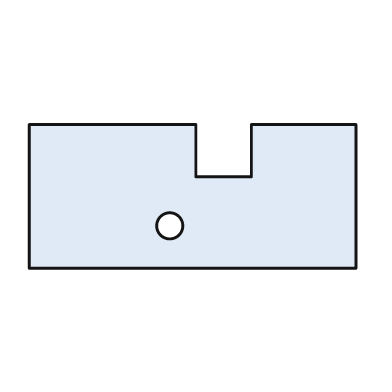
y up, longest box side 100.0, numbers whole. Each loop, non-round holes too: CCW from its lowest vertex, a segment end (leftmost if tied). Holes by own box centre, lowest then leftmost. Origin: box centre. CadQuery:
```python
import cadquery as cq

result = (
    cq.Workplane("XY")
    .moveTo(-50.0, -22.0)
    .lineTo(50.0, -22.0)
    .lineTo(50.0, 22.0)
    .lineTo(18.0, 22.0)
    .lineTo(18.0, 6.0)
    .lineTo(1.0, 6.0)
    .lineTo(1.0, 22.0)
    .lineTo(-50.0, 22.0)
    .close()
    .moveTo(-7.0, -9.0)
    .circle(4.0)
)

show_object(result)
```